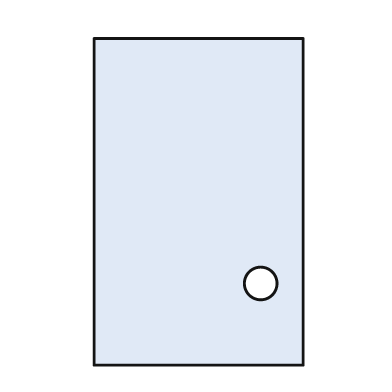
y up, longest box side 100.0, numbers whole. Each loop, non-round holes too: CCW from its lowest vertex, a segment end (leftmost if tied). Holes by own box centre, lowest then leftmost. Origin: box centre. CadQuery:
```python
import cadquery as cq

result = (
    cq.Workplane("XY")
    .moveTo(-32.0, -50.0)
    .lineTo(32.0, -50.0)
    .lineTo(32.0, 50.0)
    .lineTo(-32.0, 50.0)
    .close()
    .moveTo(19.0, -25.0)
    .circle(5.0)
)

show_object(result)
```